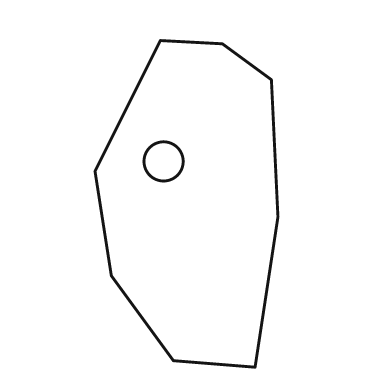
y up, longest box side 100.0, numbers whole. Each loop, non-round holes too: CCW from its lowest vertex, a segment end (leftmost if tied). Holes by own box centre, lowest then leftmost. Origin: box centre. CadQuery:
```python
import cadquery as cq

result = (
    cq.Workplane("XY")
    .moveTo(21.0, -50.0)
    .lineTo(28.0, -4.0)
    .lineTo(26.0, 38.0)
    .lineTo(11.0, 49.0)
    .lineTo(-8.0, 50.0)
    .lineTo(-28.0, 10.0)
    .lineTo(-23.0, -22.0)
    .lineTo(-4.0, -48.0)
    .close()
    .moveTo(-7.0, 13.0)
    .circle(6.0)
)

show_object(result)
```